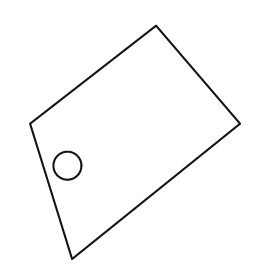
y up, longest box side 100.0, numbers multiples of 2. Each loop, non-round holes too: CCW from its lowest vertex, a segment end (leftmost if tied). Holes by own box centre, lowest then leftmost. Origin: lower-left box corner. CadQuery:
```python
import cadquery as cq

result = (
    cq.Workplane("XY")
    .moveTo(18.0, 0.0)
    .lineTo(90.0, 58.0)
    .lineTo(54.0, 100.0)
    .lineTo(0.0, 58.0)
    .close()
    .moveTo(16.0, 40.0)
    .circle(6.0)
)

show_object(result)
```